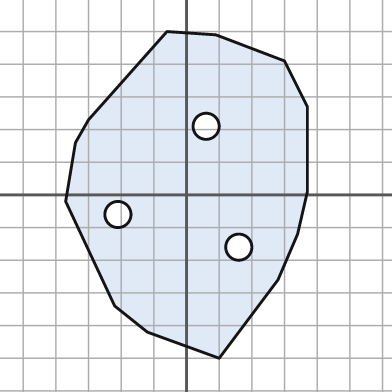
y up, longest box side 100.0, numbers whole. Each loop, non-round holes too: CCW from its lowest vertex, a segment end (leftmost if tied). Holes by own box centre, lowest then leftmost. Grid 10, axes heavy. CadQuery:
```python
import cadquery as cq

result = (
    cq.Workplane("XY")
    .moveTo(10.0, -50.0)
    .lineTo(28.0, -26.0)
    .lineTo(34.0, -12.0)
    .lineTo(37.0, 1.0)
    .lineTo(37.0, 27.0)
    .lineTo(30.0, 41.0)
    .lineTo(9.0, 49.0)
    .lineTo(-6.0, 50.0)
    .lineTo(-30.0, 23.0)
    .lineTo(-34.0, 16.0)
    .lineTo(-37.0, -2.0)
    .lineTo(-22.0, -34.0)
    .lineTo(-12.0, -42.0)
    .close()
    .moveTo(16.0, -16.0)
    .circle(4.0)
    .moveTo(-21.0, -6.0)
    .circle(4.0)
    .moveTo(6.0, 21.0)
    .circle(4.0)
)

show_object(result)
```